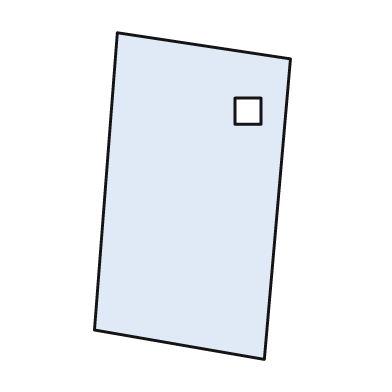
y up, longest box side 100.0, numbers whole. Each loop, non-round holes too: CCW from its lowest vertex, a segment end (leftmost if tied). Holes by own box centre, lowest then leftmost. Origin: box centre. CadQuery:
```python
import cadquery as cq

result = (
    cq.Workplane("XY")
    .moveTo(22.0, -50.0)
    .lineTo(30.0, 42.0)
    .lineTo(-23.0, 50.0)
    .lineTo(-30.0, -41.0)
    .close()
    .moveTo(13.0, 22.0)
    .lineTo(21.0, 22.0)
    .lineTo(21.0, 30.0)
    .lineTo(13.0, 30.0)
    .close()
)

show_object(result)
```